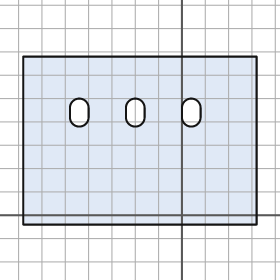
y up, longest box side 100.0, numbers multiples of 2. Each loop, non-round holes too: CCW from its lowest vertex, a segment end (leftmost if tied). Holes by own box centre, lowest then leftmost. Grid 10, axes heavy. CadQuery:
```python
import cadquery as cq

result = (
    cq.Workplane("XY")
    .moveTo(-68.0, -4.0)
    .lineTo(32.0, -4.0)
    .lineTo(32.0, 68.0)
    .lineTo(-68.0, 68.0)
    .close()
    .moveTo(-48.0, 42.0)
    .threePointArc((-44.0, 38.0), (-40.0, 42.0))
    .lineTo(-40.0, 46.0)
    .threePointArc((-44.0, 50.0), (-48.0, 46.0))
    .close()
    .moveTo(-24.0, 42.0)
    .threePointArc((-20.0, 38.0), (-16.0, 42.0))
    .lineTo(-16.0, 46.0)
    .threePointArc((-20.0, 50.0), (-24.0, 46.0))
    .close()
    .moveTo(0.0, 42.0)
    .threePointArc((4.0, 38.0), (8.0, 42.0))
    .lineTo(8.0, 46.0)
    .threePointArc((4.0, 50.0), (0.0, 46.0))
    .close()
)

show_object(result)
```